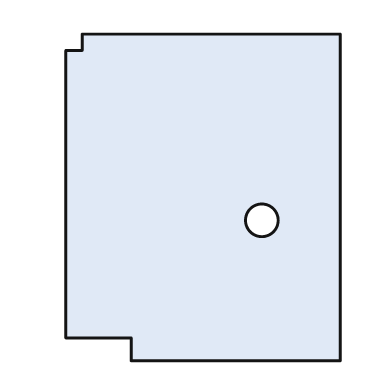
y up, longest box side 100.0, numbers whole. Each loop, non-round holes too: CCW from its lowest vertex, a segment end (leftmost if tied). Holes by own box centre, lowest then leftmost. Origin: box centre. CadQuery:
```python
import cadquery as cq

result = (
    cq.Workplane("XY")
    .moveTo(-22.0, -50.0)
    .lineTo(42.0, -50.0)
    .lineTo(42.0, 50.0)
    .lineTo(-37.0, 50.0)
    .lineTo(-37.0, 45.0)
    .lineTo(-42.0, 45.0)
    .lineTo(-42.0, -43.0)
    .lineTo(-22.0, -43.0)
    .close()
    .moveTo(18.0, -7.0)
    .circle(5.0)
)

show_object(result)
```